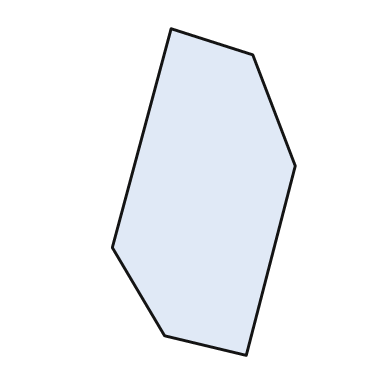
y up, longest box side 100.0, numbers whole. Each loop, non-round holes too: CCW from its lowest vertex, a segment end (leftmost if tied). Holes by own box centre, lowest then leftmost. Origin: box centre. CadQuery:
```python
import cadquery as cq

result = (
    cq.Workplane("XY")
    .moveTo(13.0, -50.0)
    .lineTo(28.0, 8.0)
    .lineTo(15.0, 42.0)
    .lineTo(-10.0, 50.0)
    .lineTo(-28.0, -17.0)
    .lineTo(-12.0, -44.0)
    .close()
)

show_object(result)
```